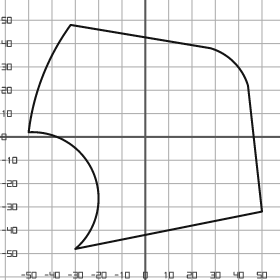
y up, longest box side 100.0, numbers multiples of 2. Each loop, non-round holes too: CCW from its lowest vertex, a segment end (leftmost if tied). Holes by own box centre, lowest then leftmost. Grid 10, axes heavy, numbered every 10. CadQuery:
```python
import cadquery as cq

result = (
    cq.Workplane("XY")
    .moveTo(-30.0, -48.0)
    .lineTo(50.0, -32.0)
    .lineTo(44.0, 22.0)
    .threePointArc((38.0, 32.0), (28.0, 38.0))
    .lineTo(-32.0, 48.0)
    .threePointArc((-44.0, 26.0), (-50.0, 2.0))
    .threePointArc((-22.0, -16.0), (-30.0, -48.0))
    .close()
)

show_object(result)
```